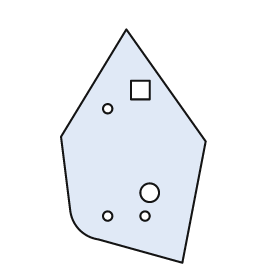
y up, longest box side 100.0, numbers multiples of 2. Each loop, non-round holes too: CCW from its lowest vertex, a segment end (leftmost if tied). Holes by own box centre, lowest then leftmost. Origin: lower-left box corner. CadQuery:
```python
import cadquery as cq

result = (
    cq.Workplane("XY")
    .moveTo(52.0, 0.0)
    .lineTo(62.0, 52.0)
    .lineTo(28.0, 100.0)
    .lineTo(0.0, 54.0)
    .lineTo(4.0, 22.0)
    .threePointArc((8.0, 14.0), (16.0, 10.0))
    .close()
    .moveTo(20.0, 20.0)
    .circle(2.0)
    .moveTo(36.0, 20.0)
    .circle(2.0)
    .moveTo(38.0, 30.0)
    .circle(4.0)
    .moveTo(20.0, 66.0)
    .circle(2.0)
    .moveTo(30.0, 70.0)
    .lineTo(38.0, 70.0)
    .lineTo(38.0, 78.0)
    .lineTo(30.0, 78.0)
    .close()
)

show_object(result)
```